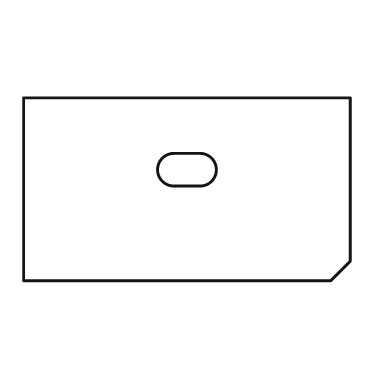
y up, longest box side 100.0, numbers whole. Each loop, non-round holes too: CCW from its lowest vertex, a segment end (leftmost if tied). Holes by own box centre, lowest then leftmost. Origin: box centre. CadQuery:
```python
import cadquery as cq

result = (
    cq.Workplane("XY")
    .moveTo(-50.0, -28.0)
    .lineTo(44.0, -28.0)
    .lineTo(50.0, -22.0)
    .lineTo(50.0, 28.0)
    .lineTo(-50.0, 28.0)
    .close()
    .moveTo(-4.0, 1.0)
    .lineTo(4.0, 1.0)
    .threePointArc((9.0, 6.0), (4.0, 11.0))
    .lineTo(-4.0, 11.0)
    .threePointArc((-9.0, 6.0), (-4.0, 1.0))
    .close()
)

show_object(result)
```